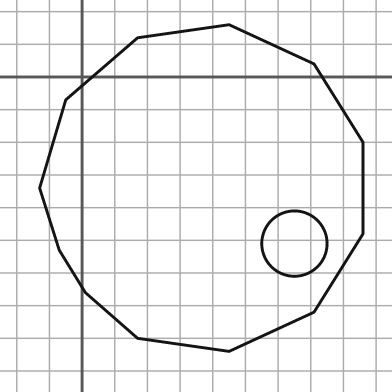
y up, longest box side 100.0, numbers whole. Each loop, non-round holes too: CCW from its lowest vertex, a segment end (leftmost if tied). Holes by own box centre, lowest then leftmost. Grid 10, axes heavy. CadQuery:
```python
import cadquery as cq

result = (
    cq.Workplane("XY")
    .moveTo(45.0, -84.0)
    .lineTo(71.0, -72.0)
    .lineTo(86.0, -48.0)
    .lineTo(86.0, -20.0)
    .lineTo(71.0, 4.0)
    .lineTo(45.0, 16.0)
    .lineTo(17.0, 12.0)
    .lineTo(-5.0, -7.0)
    .lineTo(-13.0, -34.0)
    .lineTo(-7.0, -53.0)
    .lineTo(1.0, -66.0)
    .lineTo(17.0, -80.0)
    .close()
    .moveTo(65.0, -51.0)
    .circle(10.0)
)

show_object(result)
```